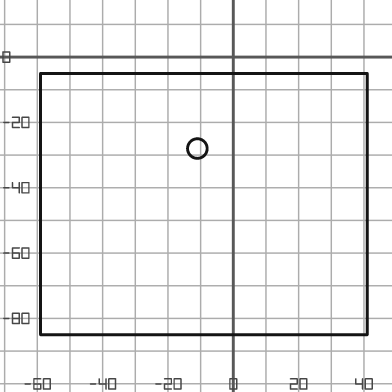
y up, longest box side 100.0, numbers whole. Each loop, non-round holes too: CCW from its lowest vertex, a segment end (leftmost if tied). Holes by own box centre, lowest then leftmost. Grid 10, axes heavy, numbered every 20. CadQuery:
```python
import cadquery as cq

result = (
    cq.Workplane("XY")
    .moveTo(-59.0, -85.0)
    .lineTo(41.0, -85.0)
    .lineTo(41.0, -5.0)
    .lineTo(-59.0, -5.0)
    .close()
    .moveTo(-11.0, -28.0)
    .circle(3.0)
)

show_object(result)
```